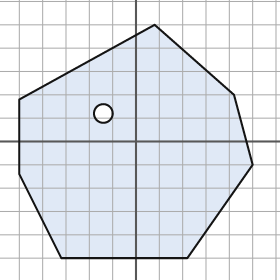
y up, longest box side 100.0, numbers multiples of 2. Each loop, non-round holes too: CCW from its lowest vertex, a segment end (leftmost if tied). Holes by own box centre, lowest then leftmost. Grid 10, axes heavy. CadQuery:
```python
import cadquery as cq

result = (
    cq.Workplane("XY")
    .moveTo(-32.0, -50.0)
    .lineTo(22.0, -50.0)
    .lineTo(50.0, -10.0)
    .lineTo(42.0, 20.0)
    .lineTo(8.0, 50.0)
    .lineTo(-50.0, 18.0)
    .lineTo(-50.0, -14.0)
    .close()
    .moveTo(-14.0, 12.0)
    .circle(4.0)
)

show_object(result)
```